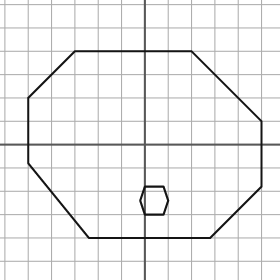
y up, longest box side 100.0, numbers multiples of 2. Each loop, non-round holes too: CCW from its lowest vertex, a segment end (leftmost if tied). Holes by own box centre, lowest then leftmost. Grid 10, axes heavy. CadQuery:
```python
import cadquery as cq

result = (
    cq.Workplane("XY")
    .moveTo(-24.0, -40.0)
    .lineTo(28.0, -40.0)
    .lineTo(50.0, -18.0)
    .lineTo(50.0, 10.0)
    .lineTo(20.0, 40.0)
    .lineTo(-30.0, 40.0)
    .lineTo(-50.0, 20.0)
    .lineTo(-50.0, -8.0)
    .close()
    .moveTo(0.0, -30.0)
    .lineTo(8.0, -30.0)
    .lineTo(10.0, -24.0)
    .lineTo(8.0, -18.0)
    .lineTo(0.0, -18.0)
    .lineTo(-2.0, -24.0)
    .close()
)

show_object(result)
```